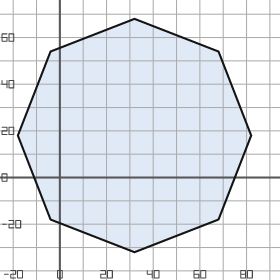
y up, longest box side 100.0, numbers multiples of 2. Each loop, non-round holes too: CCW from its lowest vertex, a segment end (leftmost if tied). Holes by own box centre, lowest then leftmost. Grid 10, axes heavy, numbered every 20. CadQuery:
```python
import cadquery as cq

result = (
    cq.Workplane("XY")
    .moveTo(32.0, -32.0)
    .lineTo(68.0, -18.0)
    .lineTo(82.0, 18.0)
    .lineTo(68.0, 54.0)
    .lineTo(32.0, 68.0)
    .lineTo(-4.0, 54.0)
    .lineTo(-18.0, 18.0)
    .lineTo(-4.0, -18.0)
    .close()
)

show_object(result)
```